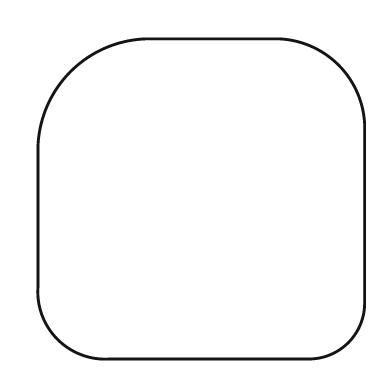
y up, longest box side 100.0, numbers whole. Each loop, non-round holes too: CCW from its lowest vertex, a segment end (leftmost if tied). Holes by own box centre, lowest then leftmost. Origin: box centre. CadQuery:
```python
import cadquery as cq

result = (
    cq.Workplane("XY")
    .moveTo(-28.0, -49.0)
    .lineTo(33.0, -49.0)
    .threePointArc((45.0, -44.0), (50.0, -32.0))
    .lineTo(50.0, 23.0)
    .threePointArc((42.0, 41.0), (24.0, 49.0))
    .lineTo(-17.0, 49.0)
    .threePointArc((-40.0, 39.0), (-50.0, 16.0))
    .lineTo(-50.0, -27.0)
    .threePointArc((-44.0, -43.0), (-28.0, -49.0))
    .close()
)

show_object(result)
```